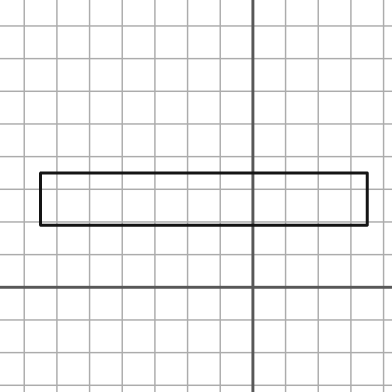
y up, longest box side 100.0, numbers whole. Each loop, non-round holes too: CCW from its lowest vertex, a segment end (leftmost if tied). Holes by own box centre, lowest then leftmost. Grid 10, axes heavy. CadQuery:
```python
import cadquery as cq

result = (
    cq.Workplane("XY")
    .moveTo(-65.0, 19.0)
    .lineTo(35.0, 19.0)
    .lineTo(35.0, 35.0)
    .lineTo(-65.0, 35.0)
    .close()
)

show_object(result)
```